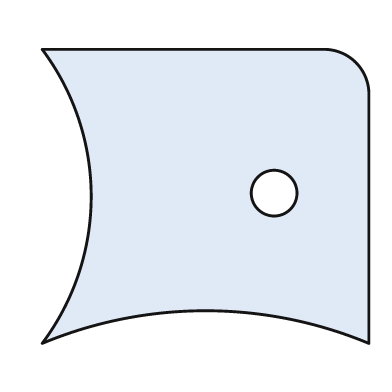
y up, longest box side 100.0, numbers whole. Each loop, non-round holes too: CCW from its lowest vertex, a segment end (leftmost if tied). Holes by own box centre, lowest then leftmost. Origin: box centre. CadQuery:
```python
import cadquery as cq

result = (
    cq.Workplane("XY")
    .moveTo(-50.0, -45.0)
    .threePointArc((0.0, -35.0), (50.0, -45.0))
    .lineTo(50.0, 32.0)
    .threePointArc((46.0, 41.0), (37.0, 45.0))
    .lineTo(-50.0, 45.0)
    .threePointArc((-35.0, 0.0), (-50.0, -45.0))
    .close()
    .moveTo(21.0, 1.0)
    .circle(7.0)
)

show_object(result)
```